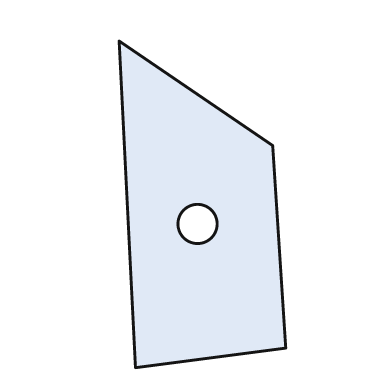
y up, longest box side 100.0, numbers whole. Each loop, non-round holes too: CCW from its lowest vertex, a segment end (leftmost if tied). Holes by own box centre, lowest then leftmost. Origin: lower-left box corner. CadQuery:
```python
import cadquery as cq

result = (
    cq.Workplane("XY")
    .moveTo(5.0, 0.0)
    .lineTo(51.0, 6.0)
    .lineTo(47.0, 68.0)
    .lineTo(0.0, 100.0)
    .close()
    .moveTo(24.0, 44.0)
    .circle(6.0)
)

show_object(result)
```